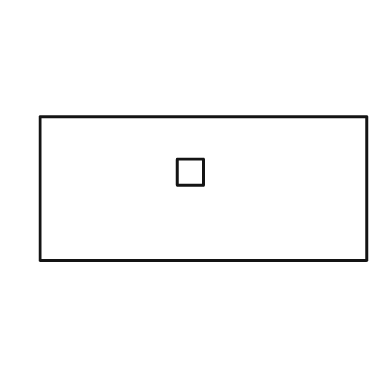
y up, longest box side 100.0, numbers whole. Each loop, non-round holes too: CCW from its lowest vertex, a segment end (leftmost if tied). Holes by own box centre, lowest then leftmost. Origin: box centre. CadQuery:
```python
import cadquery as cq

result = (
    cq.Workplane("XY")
    .moveTo(-50.0, -22.0)
    .lineTo(50.0, -22.0)
    .lineTo(50.0, 22.0)
    .lineTo(-50.0, 22.0)
    .close()
    .moveTo(-8.0, 1.0)
    .lineTo(0.0, 1.0)
    .lineTo(0.0, 9.0)
    .lineTo(-8.0, 9.0)
    .close()
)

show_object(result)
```